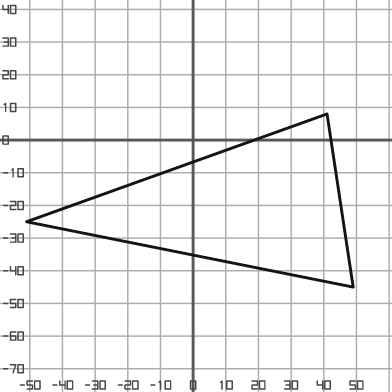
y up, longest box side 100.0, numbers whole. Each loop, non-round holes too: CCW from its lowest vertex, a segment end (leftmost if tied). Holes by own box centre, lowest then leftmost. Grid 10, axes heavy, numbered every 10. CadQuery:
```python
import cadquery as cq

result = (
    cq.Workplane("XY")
    .moveTo(49.0, -45.0)
    .lineTo(41.0, 8.0)
    .lineTo(-51.0, -25.0)
    .close()
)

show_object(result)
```